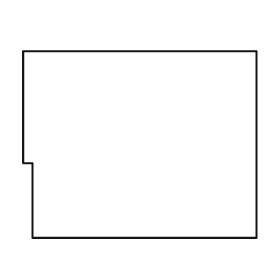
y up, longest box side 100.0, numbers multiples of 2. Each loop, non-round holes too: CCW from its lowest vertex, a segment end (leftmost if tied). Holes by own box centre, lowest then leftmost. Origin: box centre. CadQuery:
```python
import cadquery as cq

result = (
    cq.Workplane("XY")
    .moveTo(-46.0, -40.0)
    .lineTo(50.0, -40.0)
    .lineTo(50.0, 40.0)
    .lineTo(-50.0, 40.0)
    .lineTo(-50.0, -8.0)
    .lineTo(-46.0, -8.0)
    .close()
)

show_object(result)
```